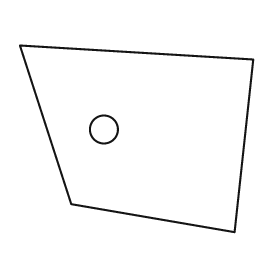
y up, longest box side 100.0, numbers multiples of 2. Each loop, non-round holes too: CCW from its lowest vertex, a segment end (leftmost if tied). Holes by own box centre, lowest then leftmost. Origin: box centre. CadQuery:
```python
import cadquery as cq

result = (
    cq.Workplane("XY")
    .moveTo(42.0, -40.0)
    .lineTo(50.0, 34.0)
    .lineTo(-50.0, 40.0)
    .lineTo(-28.0, -28.0)
    .close()
    .moveTo(-14.0, 4.0)
    .circle(6.0)
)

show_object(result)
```